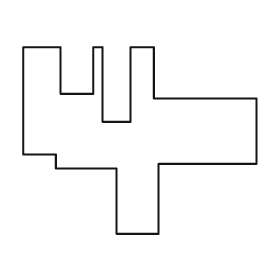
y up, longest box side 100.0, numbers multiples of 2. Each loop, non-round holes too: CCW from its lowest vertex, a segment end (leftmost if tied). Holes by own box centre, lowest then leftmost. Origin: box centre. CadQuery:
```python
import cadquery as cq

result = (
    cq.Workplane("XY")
    .moveTo(-10.0, -40.0)
    .lineTo(8.0, -40.0)
    .lineTo(8.0, -10.0)
    .lineTo(50.0, -10.0)
    .lineTo(50.0, 18.0)
    .lineTo(6.0, 18.0)
    .lineTo(6.0, 40.0)
    .lineTo(-4.0, 40.0)
    .lineTo(-4.0, 8.0)
    .lineTo(-16.0, 8.0)
    .lineTo(-16.0, 40.0)
    .lineTo(-20.0, 40.0)
    .lineTo(-20.0, 20.0)
    .lineTo(-34.0, 20.0)
    .lineTo(-34.0, 40.0)
    .lineTo(-50.0, 40.0)
    .lineTo(-50.0, -6.0)
    .lineTo(-36.0, -6.0)
    .lineTo(-36.0, -12.0)
    .lineTo(-10.0, -12.0)
    .close()
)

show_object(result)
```